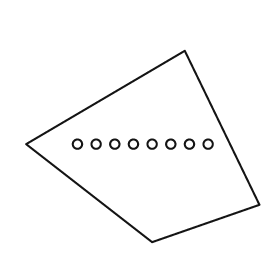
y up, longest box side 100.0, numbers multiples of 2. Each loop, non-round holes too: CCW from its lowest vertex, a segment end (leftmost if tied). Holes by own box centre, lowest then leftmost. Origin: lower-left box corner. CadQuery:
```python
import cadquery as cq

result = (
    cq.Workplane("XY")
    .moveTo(54.0, 0.0)
    .lineTo(100.0, 16.0)
    .lineTo(68.0, 82.0)
    .lineTo(0.0, 42.0)
    .close()
    .moveTo(22.0, 42.0)
    .circle(2.0)
    .moveTo(30.0, 42.0)
    .circle(2.0)
    .moveTo(38.0, 42.0)
    .circle(2.0)
    .moveTo(46.0, 42.0)
    .circle(2.0)
    .moveTo(54.0, 42.0)
    .circle(2.0)
    .moveTo(62.0, 42.0)
    .circle(2.0)
    .moveTo(70.0, 42.0)
    .circle(2.0)
    .moveTo(78.0, 42.0)
    .circle(2.0)
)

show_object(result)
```